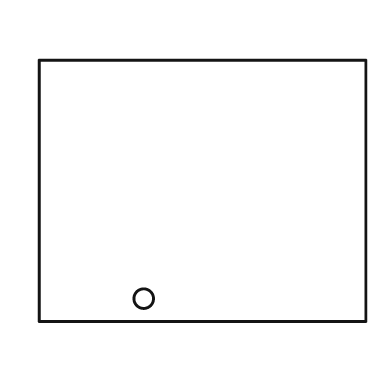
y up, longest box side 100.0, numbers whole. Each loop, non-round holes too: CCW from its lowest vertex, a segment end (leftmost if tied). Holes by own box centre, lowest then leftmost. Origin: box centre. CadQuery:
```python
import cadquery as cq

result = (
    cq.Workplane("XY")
    .moveTo(-50.0, -40.0)
    .lineTo(50.0, -40.0)
    .lineTo(50.0, 40.0)
    .lineTo(-50.0, 40.0)
    .close()
    .moveTo(-18.0, -33.0)
    .circle(3.0)
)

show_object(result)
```